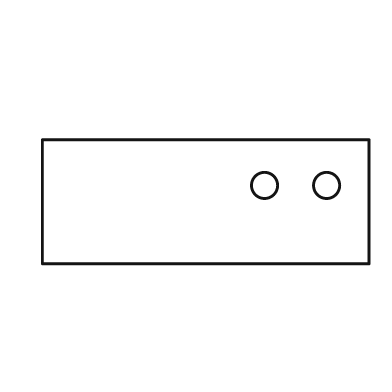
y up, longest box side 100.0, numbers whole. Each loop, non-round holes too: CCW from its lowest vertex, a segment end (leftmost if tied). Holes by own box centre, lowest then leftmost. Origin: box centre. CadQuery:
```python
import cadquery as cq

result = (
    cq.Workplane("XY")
    .moveTo(-50.0, -19.0)
    .lineTo(50.0, -19.0)
    .lineTo(50.0, 19.0)
    .lineTo(-50.0, 19.0)
    .close()
    .moveTo(18.0, 5.0)
    .circle(4.0)
    .moveTo(37.0, 5.0)
    .circle(4.0)
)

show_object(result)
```